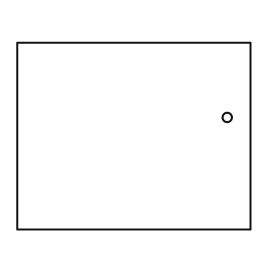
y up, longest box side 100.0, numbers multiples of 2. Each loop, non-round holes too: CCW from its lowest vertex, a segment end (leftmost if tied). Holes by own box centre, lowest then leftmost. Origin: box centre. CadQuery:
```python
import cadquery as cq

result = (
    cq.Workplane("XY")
    .moveTo(-50.0, -40.0)
    .lineTo(50.0, -40.0)
    .lineTo(50.0, 40.0)
    .lineTo(-50.0, 40.0)
    .close()
    .moveTo(40.0, 8.0)
    .circle(2.0)
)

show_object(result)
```